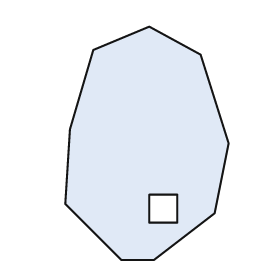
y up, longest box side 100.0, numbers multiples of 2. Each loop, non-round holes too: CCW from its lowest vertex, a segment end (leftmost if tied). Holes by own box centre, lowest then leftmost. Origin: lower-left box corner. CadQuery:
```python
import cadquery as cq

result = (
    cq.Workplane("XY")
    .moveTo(24.0, 0.0)
    .lineTo(38.0, 0.0)
    .lineTo(64.0, 20.0)
    .lineTo(70.0, 50.0)
    .lineTo(58.0, 88.0)
    .lineTo(36.0, 100.0)
    .lineTo(12.0, 90.0)
    .lineTo(2.0, 56.0)
    .lineTo(0.0, 24.0)
    .close()
    .moveTo(36.0, 16.0)
    .lineTo(48.0, 16.0)
    .lineTo(48.0, 28.0)
    .lineTo(36.0, 28.0)
    .close()
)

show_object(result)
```